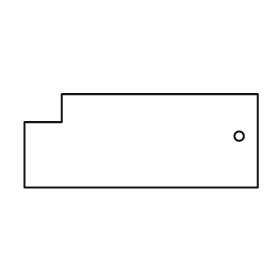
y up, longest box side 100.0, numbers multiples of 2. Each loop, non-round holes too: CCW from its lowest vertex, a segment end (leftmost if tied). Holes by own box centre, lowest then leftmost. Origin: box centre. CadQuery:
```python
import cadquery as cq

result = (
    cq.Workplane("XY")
    .moveTo(-50.0, -20.0)
    .lineTo(50.0, -20.0)
    .lineTo(50.0, 20.0)
    .lineTo(-34.0, 20.0)
    .lineTo(-34.0, 8.0)
    .lineTo(-50.0, 8.0)
    .close()
    .moveTo(42.0, 2.0)
    .circle(2.0)
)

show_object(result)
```